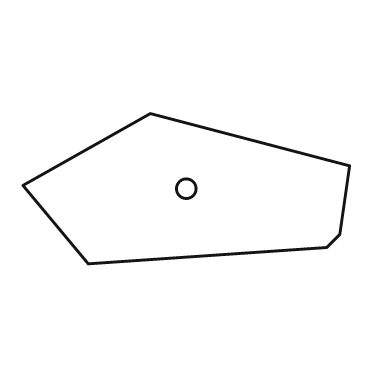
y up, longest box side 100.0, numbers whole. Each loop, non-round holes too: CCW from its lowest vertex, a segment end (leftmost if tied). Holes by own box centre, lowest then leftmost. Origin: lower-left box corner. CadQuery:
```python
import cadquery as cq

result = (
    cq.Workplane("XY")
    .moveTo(20.0, 0.0)
    .lineTo(93.0, 5.0)
    .lineTo(97.0, 9.0)
    .lineTo(100.0, 30.0)
    .lineTo(39.0, 46.0)
    .lineTo(0.0, 24.0)
    .close()
    .moveTo(50.0, 23.0)
    .circle(3.0)
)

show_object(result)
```